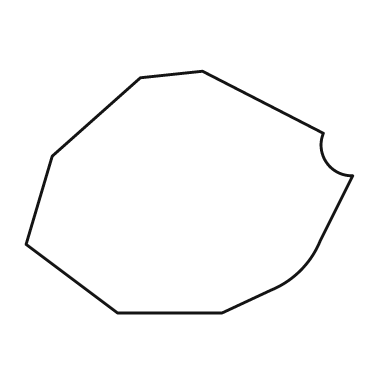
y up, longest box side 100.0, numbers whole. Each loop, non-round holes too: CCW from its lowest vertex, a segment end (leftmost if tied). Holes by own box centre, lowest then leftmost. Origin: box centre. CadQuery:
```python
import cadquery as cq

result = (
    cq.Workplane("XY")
    .moveTo(-22.0, -37.0)
    .lineTo(10.0, -37.0)
    .lineTo(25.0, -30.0)
    .threePointArc((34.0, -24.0), (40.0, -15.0))
    .lineTo(50.0, 5.0)
    .threePointArc((42.0, 9.0), (41.0, 18.0))
    .lineTo(4.0, 37.0)
    .lineTo(-15.0, 35.0)
    .lineTo(-42.0, 11.0)
    .lineTo(-50.0, -16.0)
    .close()
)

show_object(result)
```